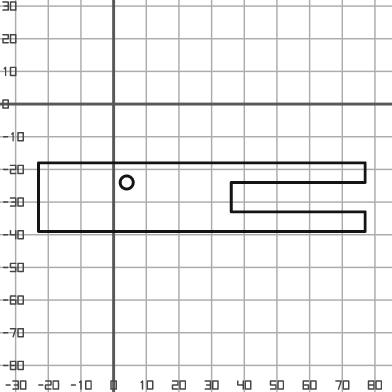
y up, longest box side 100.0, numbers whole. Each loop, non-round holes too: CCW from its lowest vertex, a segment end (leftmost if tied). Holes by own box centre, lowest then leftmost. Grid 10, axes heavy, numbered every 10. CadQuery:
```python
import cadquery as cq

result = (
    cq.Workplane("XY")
    .moveTo(-23.0, -39.0)
    .lineTo(77.0, -39.0)
    .lineTo(77.0, -33.0)
    .lineTo(36.0, -33.0)
    .lineTo(36.0, -24.0)
    .lineTo(77.0, -24.0)
    .lineTo(77.0, -18.0)
    .lineTo(-23.0, -18.0)
    .close()
    .moveTo(4.0, -24.0)
    .circle(2.0)
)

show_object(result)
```